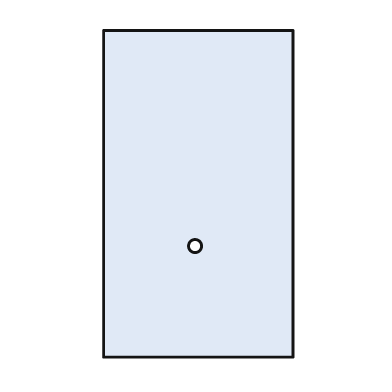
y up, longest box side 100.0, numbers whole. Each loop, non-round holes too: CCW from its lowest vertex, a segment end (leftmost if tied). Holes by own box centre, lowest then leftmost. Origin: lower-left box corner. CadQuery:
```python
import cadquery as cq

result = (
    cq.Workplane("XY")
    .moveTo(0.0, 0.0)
    .lineTo(58.0, 0.0)
    .lineTo(58.0, 100.0)
    .lineTo(0.0, 100.0)
    .close()
    .moveTo(28.0, 34.0)
    .circle(2.0)
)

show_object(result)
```